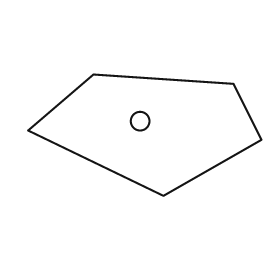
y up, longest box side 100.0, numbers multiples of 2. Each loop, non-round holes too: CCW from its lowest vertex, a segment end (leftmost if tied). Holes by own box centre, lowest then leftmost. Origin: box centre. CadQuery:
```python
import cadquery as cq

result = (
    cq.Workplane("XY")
    .moveTo(8.0, -26.0)
    .lineTo(50.0, -2.0)
    .lineTo(38.0, 22.0)
    .lineTo(-22.0, 26.0)
    .lineTo(-50.0, 2.0)
    .close()
    .moveTo(-2.0, 6.0)
    .circle(4.0)
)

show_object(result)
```